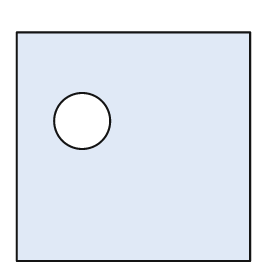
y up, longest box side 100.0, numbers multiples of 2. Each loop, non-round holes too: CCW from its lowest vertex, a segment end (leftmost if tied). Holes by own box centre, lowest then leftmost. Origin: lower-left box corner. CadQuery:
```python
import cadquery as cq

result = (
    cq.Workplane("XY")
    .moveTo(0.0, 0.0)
    .lineTo(100.0, 0.0)
    .lineTo(100.0, 98.0)
    .lineTo(0.0, 98.0)
    .close()
    .moveTo(28.0, 60.0)
    .circle(12.0)
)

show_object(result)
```